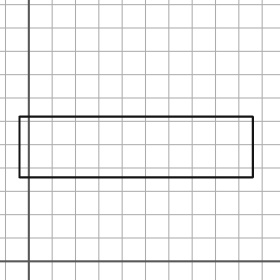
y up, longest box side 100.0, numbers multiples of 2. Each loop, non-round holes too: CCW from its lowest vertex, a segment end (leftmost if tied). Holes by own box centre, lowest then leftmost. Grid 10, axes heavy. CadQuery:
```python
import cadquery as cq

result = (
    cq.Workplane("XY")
    .moveTo(-4.0, 36.0)
    .lineTo(96.0, 36.0)
    .lineTo(96.0, 62.0)
    .lineTo(-4.0, 62.0)
    .close()
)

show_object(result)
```